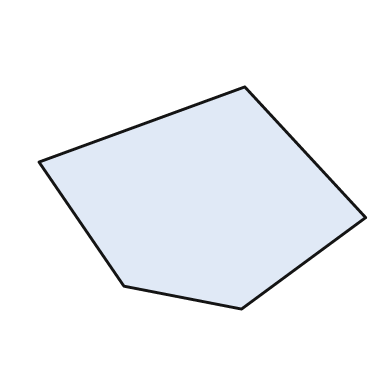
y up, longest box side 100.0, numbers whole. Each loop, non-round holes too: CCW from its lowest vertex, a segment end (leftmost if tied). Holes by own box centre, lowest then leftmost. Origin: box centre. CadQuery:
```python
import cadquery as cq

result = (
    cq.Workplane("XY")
    .moveTo(12.0, -34.0)
    .lineTo(50.0, -6.0)
    .lineTo(13.0, 34.0)
    .lineTo(-50.0, 11.0)
    .lineTo(-24.0, -27.0)
    .close()
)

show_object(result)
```